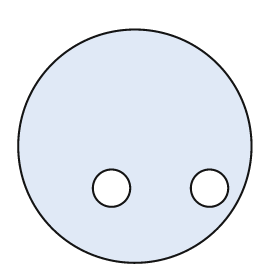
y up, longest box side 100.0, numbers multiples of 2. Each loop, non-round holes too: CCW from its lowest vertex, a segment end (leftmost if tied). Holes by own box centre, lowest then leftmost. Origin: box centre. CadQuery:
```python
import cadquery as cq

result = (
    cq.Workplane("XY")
    .moveTo(0.0, 0.0)
    .circle(50.0)
    .moveTo(-10.0, -18.0)
    .circle(8.0)
    .moveTo(32.0, -18.0)
    .circle(8.0)
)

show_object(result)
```